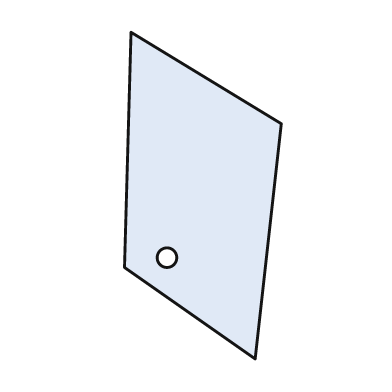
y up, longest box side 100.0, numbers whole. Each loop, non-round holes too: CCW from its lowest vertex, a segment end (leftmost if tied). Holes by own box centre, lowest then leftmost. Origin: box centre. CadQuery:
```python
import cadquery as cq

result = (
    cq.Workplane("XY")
    .moveTo(16.0, -50.0)
    .lineTo(24.0, 22.0)
    .lineTo(-22.0, 50.0)
    .lineTo(-24.0, -22.0)
    .close()
    .moveTo(-11.0, -19.0)
    .circle(3.0)
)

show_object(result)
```